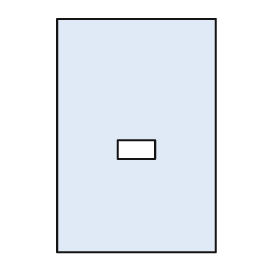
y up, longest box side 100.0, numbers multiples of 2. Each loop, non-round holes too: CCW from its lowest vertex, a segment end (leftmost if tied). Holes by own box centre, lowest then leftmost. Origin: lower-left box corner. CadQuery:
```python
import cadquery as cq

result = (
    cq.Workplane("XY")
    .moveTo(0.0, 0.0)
    .lineTo(68.0, 0.0)
    .lineTo(68.0, 100.0)
    .lineTo(0.0, 100.0)
    .close()
    .moveTo(26.0, 40.0)
    .lineTo(42.0, 40.0)
    .lineTo(42.0, 48.0)
    .lineTo(26.0, 48.0)
    .close()
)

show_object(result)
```